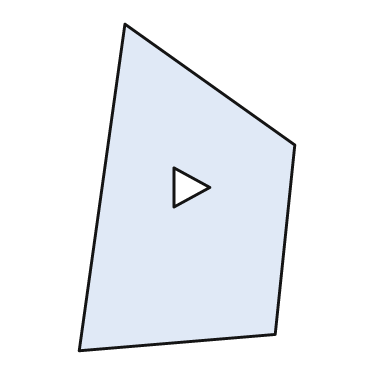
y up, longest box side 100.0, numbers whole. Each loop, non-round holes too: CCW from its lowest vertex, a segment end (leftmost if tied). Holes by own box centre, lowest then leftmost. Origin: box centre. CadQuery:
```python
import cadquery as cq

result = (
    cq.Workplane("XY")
    .moveTo(-33.0, -50.0)
    .lineTo(27.0, -45.0)
    .lineTo(33.0, 13.0)
    .lineTo(-19.0, 50.0)
    .close()
    .moveTo(-4.0, -6.0)
    .lineTo(7.0, 0.0)
    .lineTo(-4.0, 6.0)
    .close()
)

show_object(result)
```